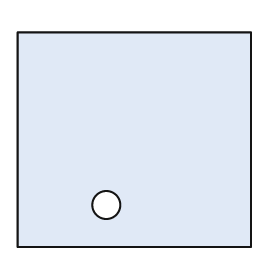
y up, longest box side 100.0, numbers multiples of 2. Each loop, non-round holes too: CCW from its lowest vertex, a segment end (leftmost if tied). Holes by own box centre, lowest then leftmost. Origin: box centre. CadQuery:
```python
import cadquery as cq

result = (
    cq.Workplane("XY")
    .moveTo(-50.0, -46.0)
    .lineTo(50.0, -46.0)
    .lineTo(50.0, 46.0)
    .lineTo(-50.0, 46.0)
    .close()
    .moveTo(-12.0, -28.0)
    .circle(6.0)
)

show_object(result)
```